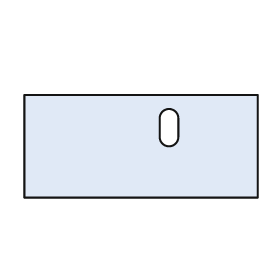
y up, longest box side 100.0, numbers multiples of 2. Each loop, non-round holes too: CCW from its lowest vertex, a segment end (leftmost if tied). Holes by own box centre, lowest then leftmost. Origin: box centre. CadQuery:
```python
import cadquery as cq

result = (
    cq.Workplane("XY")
    .moveTo(-50.0, -22.0)
    .lineTo(50.0, -22.0)
    .lineTo(50.0, 22.0)
    .lineTo(-50.0, 22.0)
    .close()
    .moveTo(8.0, 4.0)
    .threePointArc((12.0, 0.0), (16.0, 4.0))
    .lineTo(16.0, 12.0)
    .threePointArc((12.0, 16.0), (8.0, 12.0))
    .close()
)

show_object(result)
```